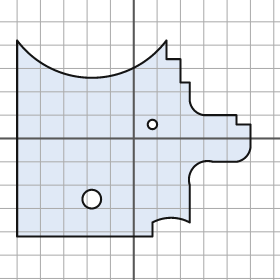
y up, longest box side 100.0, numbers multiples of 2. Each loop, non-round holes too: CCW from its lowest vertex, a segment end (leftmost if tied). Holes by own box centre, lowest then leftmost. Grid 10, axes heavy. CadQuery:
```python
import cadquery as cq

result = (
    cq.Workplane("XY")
    .moveTo(-50.0, -42.0)
    .lineTo(8.0, -42.0)
    .lineTo(8.0, -36.0)
    .threePointArc((16.0, -34.0), (24.0, -36.0))
    .lineTo(24.0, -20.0)
    .threePointArc((26.0, -12.0), (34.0, -10.0))
    .lineTo(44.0, -10.0)
    .threePointArc((48.0, -8.0), (50.0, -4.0))
    .lineTo(50.0, 6.0)
    .lineTo(44.0, 6.0)
    .lineTo(44.0, 10.0)
    .lineTo(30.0, 10.0)
    .threePointArc((26.0, 12.0), (24.0, 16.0))
    .lineTo(24.0, 24.0)
    .lineTo(20.0, 24.0)
    .lineTo(20.0, 34.0)
    .lineTo(14.0, 34.0)
    .lineTo(14.0, 42.0)
    .threePointArc((-18.0, 26.0), (-50.0, 42.0))
    .close()
    .moveTo(-18.0, -26.0)
    .circle(4.0)
    .moveTo(8.0, 6.0)
    .circle(2.0)
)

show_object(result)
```